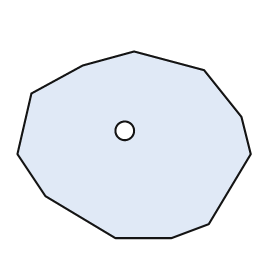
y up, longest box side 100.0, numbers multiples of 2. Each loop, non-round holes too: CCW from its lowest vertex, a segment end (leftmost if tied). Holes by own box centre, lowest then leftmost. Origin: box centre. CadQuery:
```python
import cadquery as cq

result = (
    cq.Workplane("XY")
    .moveTo(-8.0, -40.0)
    .lineTo(16.0, -40.0)
    .lineTo(32.0, -34.0)
    .lineTo(50.0, -4.0)
    .lineTo(46.0, 12.0)
    .lineTo(30.0, 32.0)
    .lineTo(0.0, 40.0)
    .lineTo(-22.0, 34.0)
    .lineTo(-44.0, 22.0)
    .lineTo(-50.0, -4.0)
    .lineTo(-38.0, -22.0)
    .close()
    .moveTo(-4.0, 6.0)
    .circle(4.0)
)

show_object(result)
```